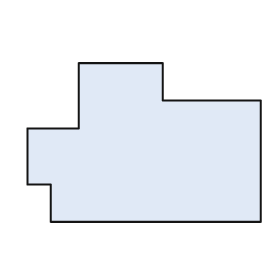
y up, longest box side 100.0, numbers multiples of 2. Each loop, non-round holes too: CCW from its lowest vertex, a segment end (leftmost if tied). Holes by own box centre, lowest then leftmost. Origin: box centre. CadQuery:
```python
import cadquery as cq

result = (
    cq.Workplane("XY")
    .moveTo(-40.0, -34.0)
    .lineTo(50.0, -34.0)
    .lineTo(50.0, 18.0)
    .lineTo(8.0, 18.0)
    .lineTo(8.0, 34.0)
    .lineTo(-28.0, 34.0)
    .lineTo(-28.0, 6.0)
    .lineTo(-50.0, 6.0)
    .lineTo(-50.0, -18.0)
    .lineTo(-40.0, -18.0)
    .close()
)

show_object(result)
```